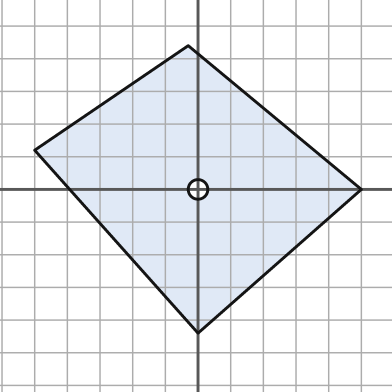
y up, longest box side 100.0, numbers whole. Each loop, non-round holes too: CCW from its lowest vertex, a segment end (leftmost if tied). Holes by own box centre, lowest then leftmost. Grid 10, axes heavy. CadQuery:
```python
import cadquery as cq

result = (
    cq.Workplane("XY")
    .moveTo(0.0, -44.0)
    .lineTo(50.0, 0.0)
    .lineTo(-3.0, 44.0)
    .lineTo(-50.0, 12.0)
    .close()
    .moveTo(0.0, 0.0)
    .circle(3.0)
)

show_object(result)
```